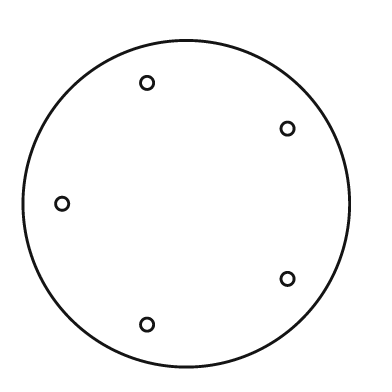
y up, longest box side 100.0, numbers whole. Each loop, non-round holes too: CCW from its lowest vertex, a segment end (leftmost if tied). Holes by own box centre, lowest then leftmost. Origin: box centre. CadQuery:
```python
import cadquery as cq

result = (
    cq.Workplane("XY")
    .moveTo(0.0, 0.0)
    .circle(50.0)
    .moveTo(-12.0, -37.0)
    .circle(2.0)
    .moveTo(31.0, -23.0)
    .circle(2.0)
    .moveTo(-38.0, 0.0)
    .circle(2.0)
    .moveTo(31.0, 23.0)
    .circle(2.0)
    .moveTo(-12.0, 37.0)
    .circle(2.0)
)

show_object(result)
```